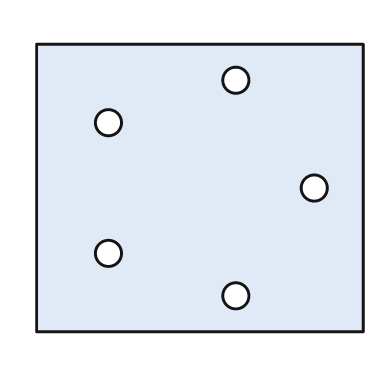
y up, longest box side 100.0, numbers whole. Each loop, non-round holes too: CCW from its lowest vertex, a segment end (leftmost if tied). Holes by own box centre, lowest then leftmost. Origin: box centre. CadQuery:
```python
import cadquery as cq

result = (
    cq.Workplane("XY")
    .moveTo(-50.0, -44.0)
    .lineTo(50.0, -44.0)
    .lineTo(50.0, 44.0)
    .lineTo(-50.0, 44.0)
    .close()
    .moveTo(11.0, -33.0)
    .circle(4.0)
    .moveTo(-28.0, -20.0)
    .circle(4.0)
    .moveTo(35.0, 0.0)
    .circle(4.0)
    .moveTo(-28.0, 20.0)
    .circle(4.0)
    .moveTo(11.0, 33.0)
    .circle(4.0)
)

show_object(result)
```